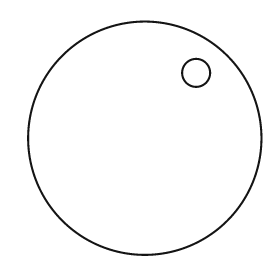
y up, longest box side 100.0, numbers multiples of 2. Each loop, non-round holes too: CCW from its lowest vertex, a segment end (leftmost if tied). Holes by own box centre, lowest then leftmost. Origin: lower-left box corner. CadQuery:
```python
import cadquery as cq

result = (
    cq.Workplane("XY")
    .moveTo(50.0, 50.0)
    .circle(50.0)
    .moveTo(72.0, 78.0)
    .circle(6.0)
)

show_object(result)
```